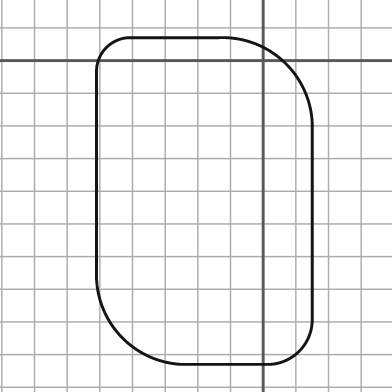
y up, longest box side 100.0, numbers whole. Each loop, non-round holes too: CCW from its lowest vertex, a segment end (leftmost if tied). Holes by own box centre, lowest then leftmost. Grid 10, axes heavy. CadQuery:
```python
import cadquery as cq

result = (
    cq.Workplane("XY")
    .moveTo(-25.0, -93.0)
    .lineTo(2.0, -93.0)
    .threePointArc((11.0, -89.0), (15.0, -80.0))
    .lineTo(15.0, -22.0)
    .threePointArc((7.0, -1.0), (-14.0, 7.0))
    .lineTo(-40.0, 7.0)
    .threePointArc((-48.0, 4.0), (-51.0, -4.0))
    .lineTo(-51.0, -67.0)
    .threePointArc((-43.0, -85.0), (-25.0, -93.0))
    .close()
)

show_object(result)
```